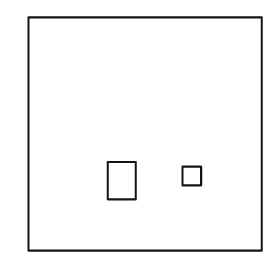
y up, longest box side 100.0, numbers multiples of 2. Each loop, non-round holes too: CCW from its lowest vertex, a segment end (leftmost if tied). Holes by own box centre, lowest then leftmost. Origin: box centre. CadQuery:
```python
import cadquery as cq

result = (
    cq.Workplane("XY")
    .moveTo(-50.0, -50.0)
    .lineTo(50.0, -50.0)
    .lineTo(50.0, 50.0)
    .lineTo(-50.0, 50.0)
    .close()
    .moveTo(-16.0, -28.0)
    .lineTo(-4.0, -28.0)
    .lineTo(-4.0, -12.0)
    .lineTo(-16.0, -12.0)
    .close()
    .moveTo(16.0, -22.0)
    .lineTo(24.0, -22.0)
    .lineTo(24.0, -14.0)
    .lineTo(16.0, -14.0)
    .close()
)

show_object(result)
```